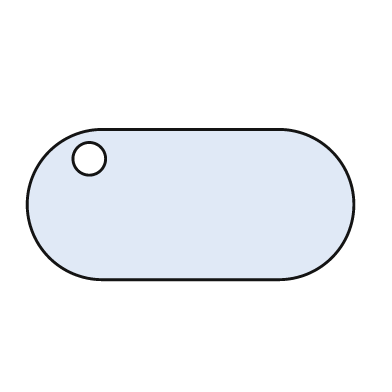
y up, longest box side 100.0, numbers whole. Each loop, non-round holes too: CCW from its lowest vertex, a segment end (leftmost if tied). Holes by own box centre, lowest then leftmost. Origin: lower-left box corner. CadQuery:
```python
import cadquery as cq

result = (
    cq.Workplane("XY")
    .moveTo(23.0, 0.0)
    .lineTo(77.0, 0.0)
    .threePointArc((100.0, 23.0), (77.0, 46.0))
    .lineTo(23.0, 46.0)
    .threePointArc((0.0, 23.0), (23.0, 0.0))
    .close()
    .moveTo(19.0, 37.0)
    .circle(5.0)
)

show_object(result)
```